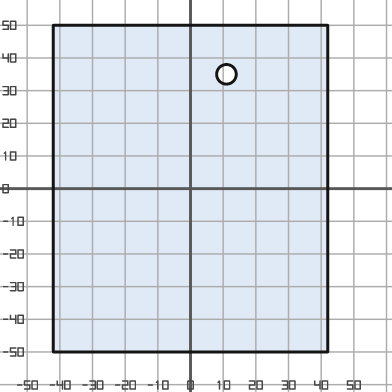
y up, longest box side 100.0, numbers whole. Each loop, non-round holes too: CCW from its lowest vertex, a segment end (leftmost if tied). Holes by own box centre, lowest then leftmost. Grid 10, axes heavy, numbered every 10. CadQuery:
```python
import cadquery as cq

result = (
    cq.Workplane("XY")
    .moveTo(-42.0, -50.0)
    .lineTo(42.0, -50.0)
    .lineTo(42.0, 50.0)
    .lineTo(-42.0, 50.0)
    .close()
    .moveTo(11.0, 35.0)
    .circle(3.0)
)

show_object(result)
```